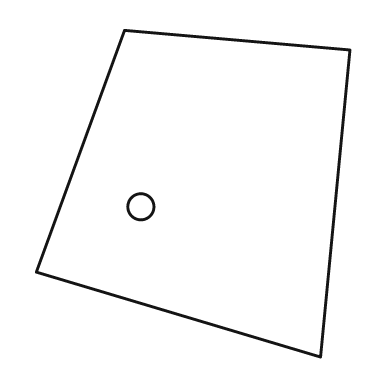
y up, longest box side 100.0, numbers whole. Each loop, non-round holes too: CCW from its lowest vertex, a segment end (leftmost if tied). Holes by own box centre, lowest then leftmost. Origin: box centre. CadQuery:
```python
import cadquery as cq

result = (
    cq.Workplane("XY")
    .moveTo(39.0, -50.0)
    .lineTo(48.0, 44.0)
    .lineTo(-21.0, 50.0)
    .lineTo(-48.0, -24.0)
    .close()
    .moveTo(-16.0, -4.0)
    .circle(4.0)
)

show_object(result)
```